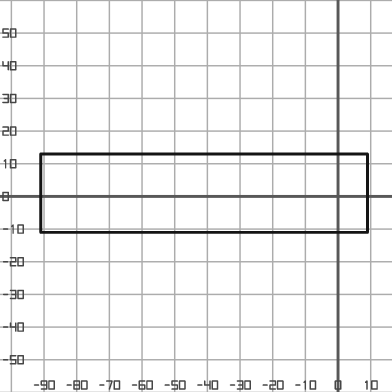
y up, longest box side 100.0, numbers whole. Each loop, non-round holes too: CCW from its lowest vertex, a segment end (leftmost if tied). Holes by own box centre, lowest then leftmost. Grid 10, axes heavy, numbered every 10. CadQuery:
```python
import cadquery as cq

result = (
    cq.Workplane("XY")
    .moveTo(-91.0, -11.0)
    .lineTo(9.0, -11.0)
    .lineTo(9.0, 13.0)
    .lineTo(-91.0, 13.0)
    .close()
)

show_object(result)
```